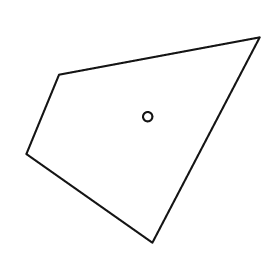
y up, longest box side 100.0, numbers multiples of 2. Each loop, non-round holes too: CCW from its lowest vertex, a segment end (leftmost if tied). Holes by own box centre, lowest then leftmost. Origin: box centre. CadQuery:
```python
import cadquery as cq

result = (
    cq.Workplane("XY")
    .moveTo(4.0, -44.0)
    .lineTo(50.0, 44.0)
    .lineTo(-36.0, 28.0)
    .lineTo(-50.0, -6.0)
    .close()
    .moveTo(2.0, 10.0)
    .circle(2.0)
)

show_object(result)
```